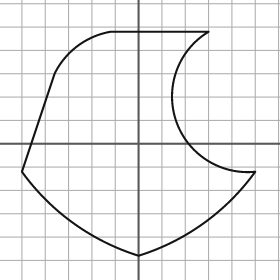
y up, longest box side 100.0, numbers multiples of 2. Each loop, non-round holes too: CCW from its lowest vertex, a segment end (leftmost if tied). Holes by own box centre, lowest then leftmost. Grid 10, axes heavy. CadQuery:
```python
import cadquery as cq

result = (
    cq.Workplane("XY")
    .moveTo(0.0, -48.0)
    .threePointArc((28.0, -34.0), (50.0, -12.0))
    .threePointArc((16.0, 10.0), (30.0, 48.0))
    .lineTo(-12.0, 48.0)
    .threePointArc((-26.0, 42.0), (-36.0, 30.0))
    .lineTo(-50.0, -12.0)
    .threePointArc((-28.0, -34.0), (0.0, -48.0))
    .close()
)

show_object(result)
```